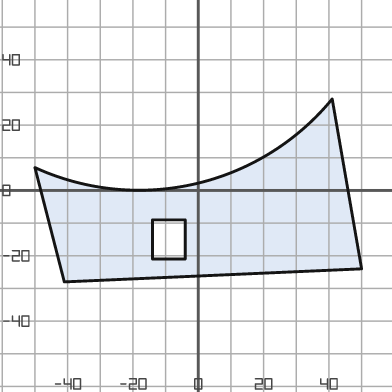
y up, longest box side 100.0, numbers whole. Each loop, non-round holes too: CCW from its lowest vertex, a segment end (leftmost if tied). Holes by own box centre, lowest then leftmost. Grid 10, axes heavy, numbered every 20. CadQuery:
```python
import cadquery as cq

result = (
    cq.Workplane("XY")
    .moveTo(-41.0, -28.0)
    .lineTo(50.0, -24.0)
    .lineTo(41.0, 28.0)
    .threePointArc((-1.0, 2.0), (-50.0, 7.0))
    .close()
    .moveTo(-14.0, -21.0)
    .lineTo(-4.0, -21.0)
    .lineTo(-4.0, -9.0)
    .lineTo(-14.0, -9.0)
    .close()
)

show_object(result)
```